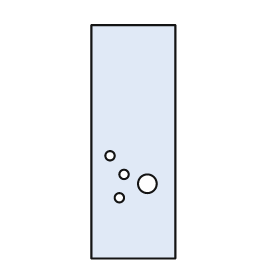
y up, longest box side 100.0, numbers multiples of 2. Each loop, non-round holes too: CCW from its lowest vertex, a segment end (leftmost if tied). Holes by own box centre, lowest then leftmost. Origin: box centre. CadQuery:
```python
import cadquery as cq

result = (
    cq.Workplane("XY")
    .moveTo(-18.0, -50.0)
    .lineTo(18.0, -50.0)
    .lineTo(18.0, 50.0)
    .lineTo(-18.0, 50.0)
    .close()
    .moveTo(-6.0, -24.0)
    .circle(2.0)
    .moveTo(6.0, -18.0)
    .circle(4.0)
    .moveTo(-4.0, -14.0)
    .circle(2.0)
    .moveTo(-10.0, -6.0)
    .circle(2.0)
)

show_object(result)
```